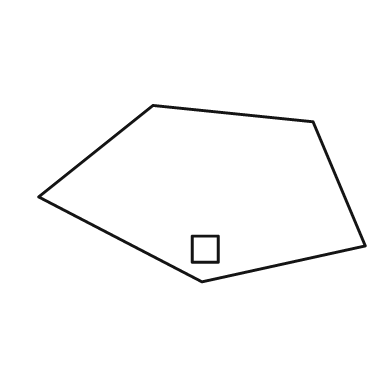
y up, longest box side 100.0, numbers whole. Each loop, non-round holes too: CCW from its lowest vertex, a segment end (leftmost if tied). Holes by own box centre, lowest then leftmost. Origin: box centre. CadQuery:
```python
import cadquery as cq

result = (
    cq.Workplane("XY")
    .moveTo(0.0, -27.0)
    .lineTo(50.0, -16.0)
    .lineTo(34.0, 22.0)
    .lineTo(-15.0, 27.0)
    .lineTo(-50.0, -1.0)
    .close()
    .moveTo(-3.0, -21.0)
    .lineTo(5.0, -21.0)
    .lineTo(5.0, -13.0)
    .lineTo(-3.0, -13.0)
    .close()
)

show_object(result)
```